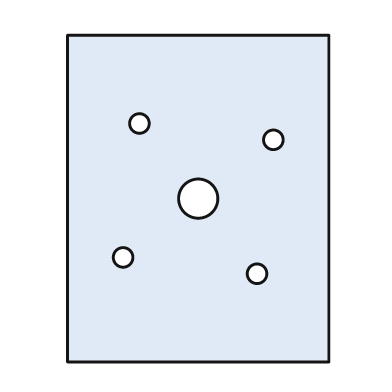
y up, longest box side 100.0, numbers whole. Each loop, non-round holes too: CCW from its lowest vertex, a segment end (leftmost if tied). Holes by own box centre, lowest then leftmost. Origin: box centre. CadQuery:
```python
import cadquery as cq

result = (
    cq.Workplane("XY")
    .moveTo(-40.0, -50.0)
    .lineTo(40.0, -50.0)
    .lineTo(40.0, 50.0)
    .lineTo(-40.0, 50.0)
    .close()
    .moveTo(18.0, -23.0)
    .circle(3.0)
    .moveTo(-23.0, -18.0)
    .circle(3.0)
    .moveTo(0.0, 0.0)
    .circle(6.0)
    .moveTo(23.0, 18.0)
    .circle(3.0)
    .moveTo(-18.0, 23.0)
    .circle(3.0)
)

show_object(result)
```